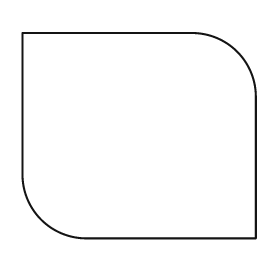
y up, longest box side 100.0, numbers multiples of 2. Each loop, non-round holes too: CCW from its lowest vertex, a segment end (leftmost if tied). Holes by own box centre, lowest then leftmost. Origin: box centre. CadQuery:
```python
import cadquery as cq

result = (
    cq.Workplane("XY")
    .moveTo(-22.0, -44.0)
    .lineTo(50.0, -44.0)
    .lineTo(50.0, 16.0)
    .threePointArc((42.0, 36.0), (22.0, 44.0))
    .lineTo(-50.0, 44.0)
    .lineTo(-50.0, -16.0)
    .threePointArc((-42.0, -36.0), (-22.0, -44.0))
    .close()
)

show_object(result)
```